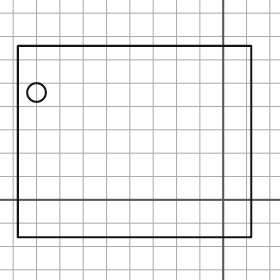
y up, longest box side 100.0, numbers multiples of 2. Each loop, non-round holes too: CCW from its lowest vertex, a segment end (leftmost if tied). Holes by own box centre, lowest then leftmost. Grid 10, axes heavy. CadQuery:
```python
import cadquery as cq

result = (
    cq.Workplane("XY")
    .moveTo(-88.0, -16.0)
    .lineTo(12.0, -16.0)
    .lineTo(12.0, 66.0)
    .lineTo(-88.0, 66.0)
    .close()
    .moveTo(-80.0, 46.0)
    .circle(4.0)
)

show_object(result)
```